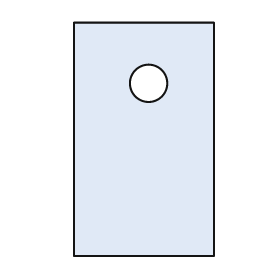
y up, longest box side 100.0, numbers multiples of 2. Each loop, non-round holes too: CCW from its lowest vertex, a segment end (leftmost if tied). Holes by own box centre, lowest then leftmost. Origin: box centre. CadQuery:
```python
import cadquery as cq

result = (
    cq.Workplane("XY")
    .moveTo(-30.0, -50.0)
    .lineTo(30.0, -50.0)
    .lineTo(30.0, 50.0)
    .lineTo(-30.0, 50.0)
    .close()
    .moveTo(2.0, 24.0)
    .circle(8.0)
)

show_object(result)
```